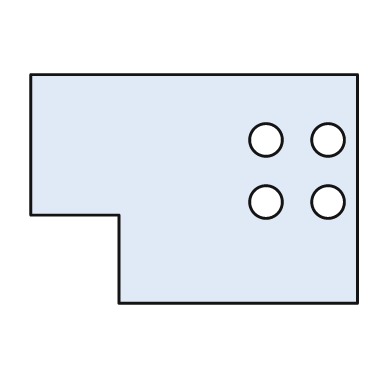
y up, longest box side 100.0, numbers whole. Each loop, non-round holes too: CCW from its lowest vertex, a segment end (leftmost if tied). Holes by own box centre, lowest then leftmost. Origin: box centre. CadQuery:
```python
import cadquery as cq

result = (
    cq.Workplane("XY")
    .moveTo(-23.0, -35.0)
    .lineTo(50.0, -35.0)
    .lineTo(50.0, 35.0)
    .lineTo(-50.0, 35.0)
    .lineTo(-50.0, -8.0)
    .lineTo(-23.0, -8.0)
    .close()
    .moveTo(22.0, -4.0)
    .circle(5.0)
    .moveTo(41.0, -4.0)
    .circle(5.0)
    .moveTo(22.0, 15.0)
    .circle(5.0)
    .moveTo(41.0, 15.0)
    .circle(5.0)
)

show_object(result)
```